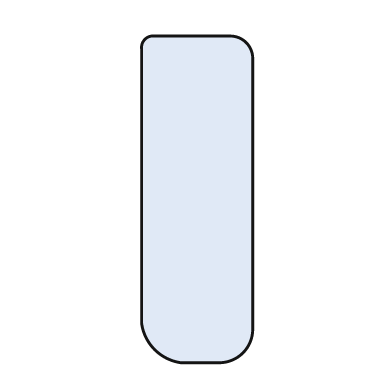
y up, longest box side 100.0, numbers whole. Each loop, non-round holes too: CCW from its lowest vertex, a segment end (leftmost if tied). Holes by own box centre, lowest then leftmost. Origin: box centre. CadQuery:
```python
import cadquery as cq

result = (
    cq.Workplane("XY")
    .moveTo(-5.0, -50.0)
    .lineTo(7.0, -50.0)
    .threePointArc((14.0, -47.0), (17.0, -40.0))
    .lineTo(17.0, 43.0)
    .threePointArc((15.0, 48.0), (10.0, 50.0))
    .lineTo(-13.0, 50.0)
    .threePointArc((-16.0, 49.0), (-17.0, 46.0))
    .lineTo(-17.0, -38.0)
    .threePointArc((-13.0, -46.0), (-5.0, -50.0))
    .close()
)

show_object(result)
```